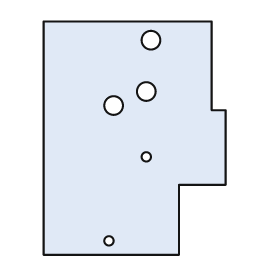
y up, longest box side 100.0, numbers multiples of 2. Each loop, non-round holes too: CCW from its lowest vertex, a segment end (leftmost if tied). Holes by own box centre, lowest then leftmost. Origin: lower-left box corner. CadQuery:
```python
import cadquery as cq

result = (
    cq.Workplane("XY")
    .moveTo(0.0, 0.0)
    .lineTo(58.0, 0.0)
    .lineTo(58.0, 30.0)
    .lineTo(78.0, 30.0)
    .lineTo(78.0, 62.0)
    .lineTo(72.0, 62.0)
    .lineTo(72.0, 100.0)
    .lineTo(0.0, 100.0)
    .close()
    .moveTo(28.0, 6.0)
    .circle(2.0)
    .moveTo(44.0, 42.0)
    .circle(2.0)
    .moveTo(30.0, 64.0)
    .circle(4.0)
    .moveTo(44.0, 70.0)
    .circle(4.0)
    .moveTo(46.0, 92.0)
    .circle(4.0)
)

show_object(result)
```